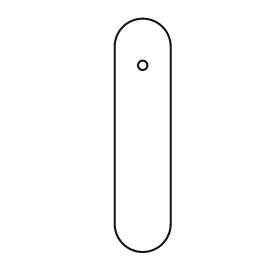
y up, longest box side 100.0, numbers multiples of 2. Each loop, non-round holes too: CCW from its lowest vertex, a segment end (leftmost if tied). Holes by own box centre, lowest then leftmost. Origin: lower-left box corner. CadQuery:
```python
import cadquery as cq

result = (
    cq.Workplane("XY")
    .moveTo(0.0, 12.0)
    .threePointArc((12.0, 0.0), (24.0, 12.0))
    .lineTo(24.0, 88.0)
    .threePointArc((12.0, 100.0), (0.0, 88.0))
    .close()
    .moveTo(12.0, 80.0)
    .circle(2.0)
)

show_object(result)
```